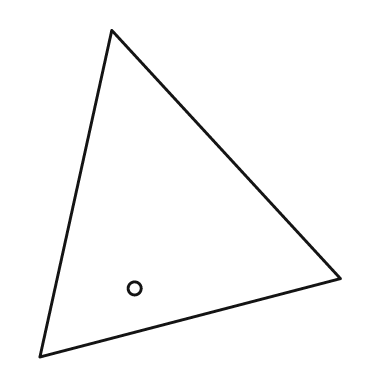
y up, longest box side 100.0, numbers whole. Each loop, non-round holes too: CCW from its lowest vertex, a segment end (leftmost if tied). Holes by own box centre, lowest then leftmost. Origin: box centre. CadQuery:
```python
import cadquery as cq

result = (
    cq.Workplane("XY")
    .moveTo(-46.0, -50.0)
    .lineTo(46.0, -26.0)
    .lineTo(-24.0, 50.0)
    .close()
    .moveTo(-17.0, -29.0)
    .circle(2.0)
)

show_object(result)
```